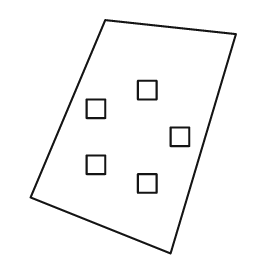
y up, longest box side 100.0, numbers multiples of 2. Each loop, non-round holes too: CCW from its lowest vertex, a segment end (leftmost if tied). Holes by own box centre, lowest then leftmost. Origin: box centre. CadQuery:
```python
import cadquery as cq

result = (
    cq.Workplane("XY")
    .moveTo(16.0, -50.0)
    .lineTo(44.0, 44.0)
    .lineTo(-12.0, 50.0)
    .lineTo(-44.0, -26.0)
    .close()
    .moveTo(2.0, -24.0)
    .lineTo(10.0, -24.0)
    .lineTo(10.0, -16.0)
    .lineTo(2.0, -16.0)
    .close()
    .moveTo(-20.0, -16.0)
    .lineTo(-12.0, -16.0)
    .lineTo(-12.0, -8.0)
    .lineTo(-20.0, -8.0)
    .close()
    .moveTo(16.0, -4.0)
    .lineTo(24.0, -4.0)
    .lineTo(24.0, 4.0)
    .lineTo(16.0, 4.0)
    .close()
    .moveTo(-20.0, 8.0)
    .lineTo(-12.0, 8.0)
    .lineTo(-12.0, 16.0)
    .lineTo(-20.0, 16.0)
    .close()
    .moveTo(2.0, 16.0)
    .lineTo(10.0, 16.0)
    .lineTo(10.0, 24.0)
    .lineTo(2.0, 24.0)
    .close()
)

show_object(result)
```